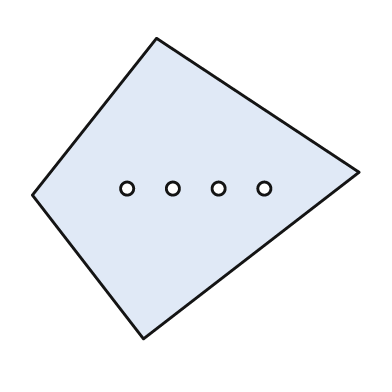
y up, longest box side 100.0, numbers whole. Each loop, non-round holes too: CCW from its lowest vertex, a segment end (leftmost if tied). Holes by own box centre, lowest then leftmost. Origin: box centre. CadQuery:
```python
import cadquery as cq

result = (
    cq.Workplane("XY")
    .moveTo(-16.0, -46.0)
    .lineTo(50.0, 5.0)
    .lineTo(-12.0, 46.0)
    .lineTo(-50.0, -2.0)
    .close()
    .moveTo(-21.0, 0.0)
    .circle(2.0)
    .moveTo(-7.0, 0.0)
    .circle(2.0)
    .moveTo(7.0, 0.0)
    .circle(2.0)
    .moveTo(21.0, 0.0)
    .circle(2.0)
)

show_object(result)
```